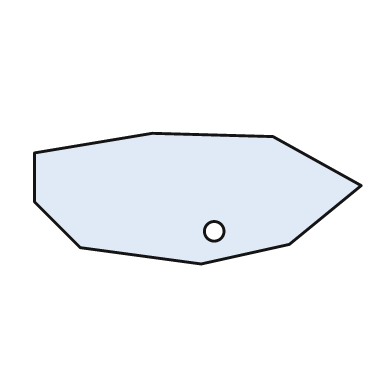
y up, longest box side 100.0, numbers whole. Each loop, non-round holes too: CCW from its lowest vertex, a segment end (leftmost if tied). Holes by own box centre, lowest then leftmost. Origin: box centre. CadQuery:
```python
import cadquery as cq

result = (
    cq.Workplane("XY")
    .moveTo(1.0, -20.0)
    .lineTo(28.0, -14.0)
    .lineTo(50.0, 4.0)
    .lineTo(23.0, 19.0)
    .lineTo(-14.0, 20.0)
    .lineTo(-50.0, 14.0)
    .lineTo(-50.0, -1.0)
    .lineTo(-36.0, -15.0)
    .close()
    .moveTo(5.0, -10.0)
    .circle(3.0)
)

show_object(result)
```